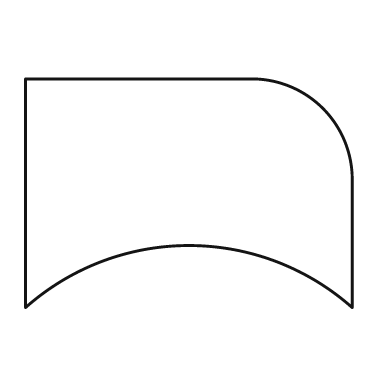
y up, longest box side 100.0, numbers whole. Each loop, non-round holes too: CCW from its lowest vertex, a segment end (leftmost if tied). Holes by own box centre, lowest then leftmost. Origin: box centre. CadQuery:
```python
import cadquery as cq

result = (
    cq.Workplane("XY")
    .moveTo(-50.0, -35.0)
    .threePointArc((0.0, -16.0), (50.0, -35.0))
    .lineTo(50.0, 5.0)
    .threePointArc((41.0, 26.0), (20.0, 35.0))
    .lineTo(-50.0, 35.0)
    .close()
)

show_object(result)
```